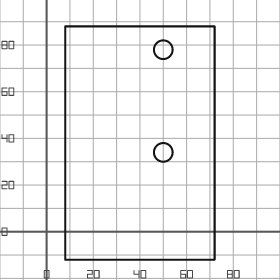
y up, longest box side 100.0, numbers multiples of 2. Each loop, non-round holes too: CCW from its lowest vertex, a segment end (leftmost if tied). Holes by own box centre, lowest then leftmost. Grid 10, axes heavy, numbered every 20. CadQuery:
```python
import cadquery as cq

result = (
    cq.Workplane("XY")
    .moveTo(8.0, -12.0)
    .lineTo(72.0, -12.0)
    .lineTo(72.0, 88.0)
    .lineTo(8.0, 88.0)
    .close()
    .moveTo(50.0, 34.0)
    .circle(4.0)
    .moveTo(50.0, 78.0)
    .circle(4.0)
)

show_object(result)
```